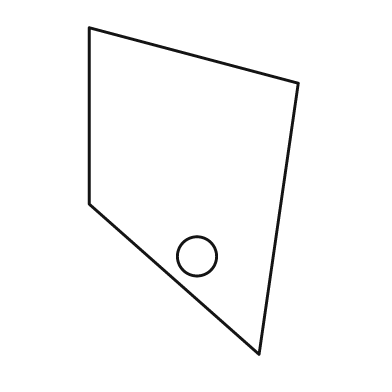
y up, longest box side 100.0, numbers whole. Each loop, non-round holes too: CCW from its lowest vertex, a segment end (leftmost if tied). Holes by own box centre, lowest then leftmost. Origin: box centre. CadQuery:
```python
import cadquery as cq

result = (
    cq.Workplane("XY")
    .moveTo(20.0, -50.0)
    .lineTo(32.0, 33.0)
    .lineTo(-32.0, 50.0)
    .lineTo(-32.0, -4.0)
    .close()
    .moveTo(1.0, -20.0)
    .circle(6.0)
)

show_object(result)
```